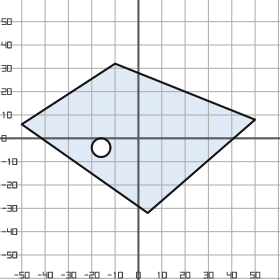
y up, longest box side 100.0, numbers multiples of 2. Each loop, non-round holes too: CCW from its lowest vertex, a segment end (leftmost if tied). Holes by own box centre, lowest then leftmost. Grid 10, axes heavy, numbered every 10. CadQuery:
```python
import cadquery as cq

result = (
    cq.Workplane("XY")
    .moveTo(4.0, -32.0)
    .lineTo(50.0, 8.0)
    .lineTo(-10.0, 32.0)
    .lineTo(-50.0, 6.0)
    .close()
    .moveTo(-16.0, -4.0)
    .circle(4.0)
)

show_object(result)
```